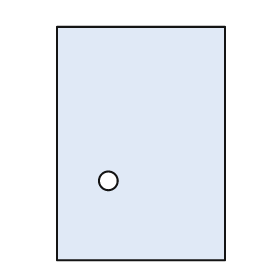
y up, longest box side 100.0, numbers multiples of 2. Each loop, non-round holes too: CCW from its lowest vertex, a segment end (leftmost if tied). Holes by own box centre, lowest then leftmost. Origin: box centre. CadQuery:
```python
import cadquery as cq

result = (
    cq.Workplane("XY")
    .moveTo(-36.0, -50.0)
    .lineTo(36.0, -50.0)
    .lineTo(36.0, 50.0)
    .lineTo(-36.0, 50.0)
    .close()
    .moveTo(-14.0, -16.0)
    .circle(4.0)
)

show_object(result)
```